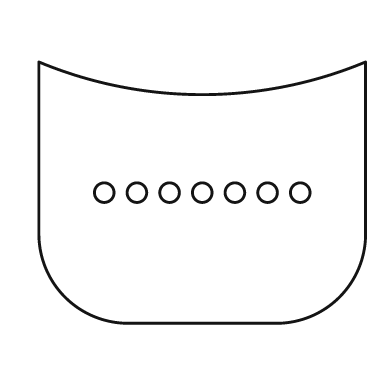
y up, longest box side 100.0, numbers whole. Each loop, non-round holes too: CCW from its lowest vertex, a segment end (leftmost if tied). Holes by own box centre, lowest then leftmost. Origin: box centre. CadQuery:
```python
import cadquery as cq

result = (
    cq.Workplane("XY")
    .moveTo(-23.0, -40.0)
    .lineTo(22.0, -40.0)
    .threePointArc((42.0, -32.0), (50.0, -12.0))
    .lineTo(50.0, 40.0)
    .threePointArc((0.0, 30.0), (-50.0, 40.0))
    .lineTo(-50.0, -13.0)
    .threePointArc((-42.0, -32.0), (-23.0, -40.0))
    .close()
    .moveTo(-30.0, 0.0)
    .circle(3.0)
    .moveTo(-20.0, 0.0)
    .circle(3.0)
    .moveTo(-10.0, 0.0)
    .circle(3.0)
    .moveTo(0.0, 0.0)
    .circle(3.0)
    .moveTo(10.0, 0.0)
    .circle(3.0)
    .moveTo(20.0, 0.0)
    .circle(3.0)
    .moveTo(30.0, 0.0)
    .circle(3.0)
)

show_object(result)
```